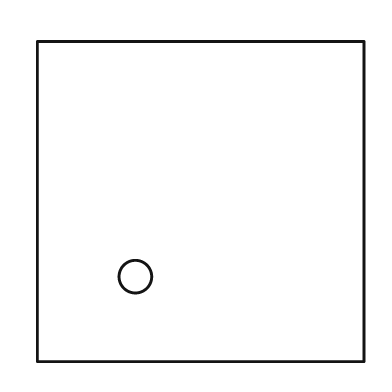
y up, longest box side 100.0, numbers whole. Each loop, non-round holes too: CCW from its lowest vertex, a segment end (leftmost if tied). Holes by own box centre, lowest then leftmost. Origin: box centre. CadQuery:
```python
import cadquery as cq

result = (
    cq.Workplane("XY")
    .moveTo(-50.0, -49.0)
    .lineTo(50.0, -49.0)
    .lineTo(50.0, 49.0)
    .lineTo(-50.0, 49.0)
    .close()
    .moveTo(-20.0, -23.0)
    .circle(5.0)
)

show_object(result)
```